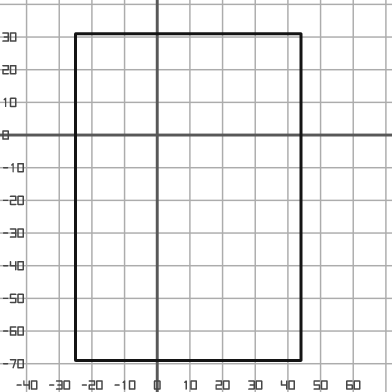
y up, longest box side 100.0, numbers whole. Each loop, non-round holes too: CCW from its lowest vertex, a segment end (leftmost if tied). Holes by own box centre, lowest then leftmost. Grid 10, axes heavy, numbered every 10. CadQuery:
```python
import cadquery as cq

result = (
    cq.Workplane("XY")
    .moveTo(-25.0, -69.0)
    .lineTo(44.0, -69.0)
    .lineTo(44.0, 31.0)
    .lineTo(-25.0, 31.0)
    .close()
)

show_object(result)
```